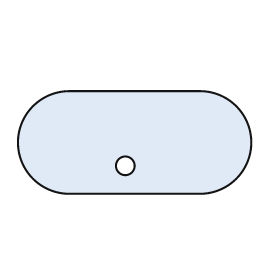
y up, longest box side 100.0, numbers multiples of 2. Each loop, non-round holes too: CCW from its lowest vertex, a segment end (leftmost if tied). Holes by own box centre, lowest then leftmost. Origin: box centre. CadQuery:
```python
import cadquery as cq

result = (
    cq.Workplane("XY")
    .moveTo(-28.0, -22.0)
    .lineTo(28.0, -22.0)
    .threePointArc((50.0, 0.0), (28.0, 22.0))
    .lineTo(-28.0, 22.0)
    .threePointArc((-50.0, 0.0), (-28.0, -22.0))
    .close()
    .moveTo(-4.0, -10.0)
    .circle(4.0)
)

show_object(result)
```